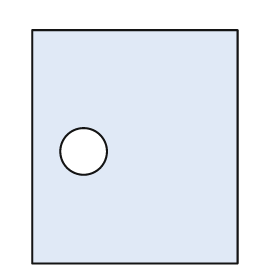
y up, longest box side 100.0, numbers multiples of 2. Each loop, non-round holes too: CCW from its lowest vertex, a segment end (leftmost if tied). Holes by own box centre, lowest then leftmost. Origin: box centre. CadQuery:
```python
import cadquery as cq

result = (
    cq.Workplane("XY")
    .moveTo(-44.0, -50.0)
    .lineTo(44.0, -50.0)
    .lineTo(44.0, 50.0)
    .lineTo(-44.0, 50.0)
    .close()
    .moveTo(-22.0, -2.0)
    .circle(10.0)
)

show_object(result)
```